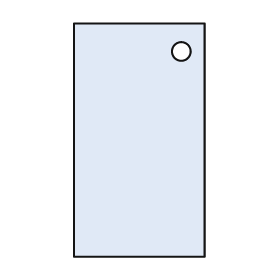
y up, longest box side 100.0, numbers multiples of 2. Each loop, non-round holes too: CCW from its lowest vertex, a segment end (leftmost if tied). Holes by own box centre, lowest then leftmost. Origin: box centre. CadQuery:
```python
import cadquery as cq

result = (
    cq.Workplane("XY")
    .moveTo(-28.0, -50.0)
    .lineTo(28.0, -50.0)
    .lineTo(28.0, 50.0)
    .lineTo(-28.0, 50.0)
    .close()
    .moveTo(18.0, 38.0)
    .circle(4.0)
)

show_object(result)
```